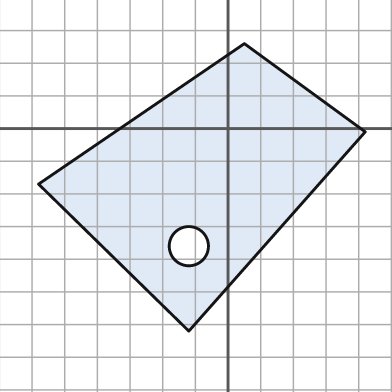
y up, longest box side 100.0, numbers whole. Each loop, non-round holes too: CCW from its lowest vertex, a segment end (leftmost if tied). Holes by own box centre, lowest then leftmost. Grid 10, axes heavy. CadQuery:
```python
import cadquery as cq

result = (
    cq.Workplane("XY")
    .moveTo(-12.0, -62.0)
    .lineTo(42.0, -1.0)
    .lineTo(5.0, 26.0)
    .lineTo(-58.0, -17.0)
    .close()
    .moveTo(-12.0, -36.0)
    .circle(6.0)
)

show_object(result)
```